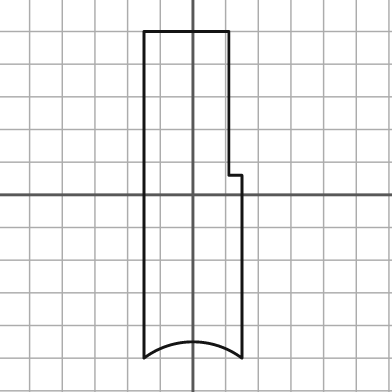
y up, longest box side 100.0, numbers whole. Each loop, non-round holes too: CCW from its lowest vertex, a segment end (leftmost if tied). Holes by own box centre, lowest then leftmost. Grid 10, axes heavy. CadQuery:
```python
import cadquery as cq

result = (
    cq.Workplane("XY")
    .moveTo(-15.0, -50.0)
    .threePointArc((0.0, -45.0), (15.0, -50.0))
    .lineTo(15.0, 6.0)
    .lineTo(11.0, 6.0)
    .lineTo(11.0, 50.0)
    .lineTo(-15.0, 50.0)
    .close()
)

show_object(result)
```